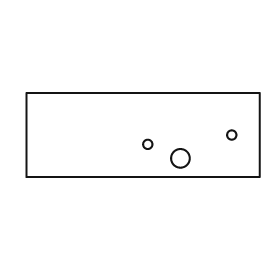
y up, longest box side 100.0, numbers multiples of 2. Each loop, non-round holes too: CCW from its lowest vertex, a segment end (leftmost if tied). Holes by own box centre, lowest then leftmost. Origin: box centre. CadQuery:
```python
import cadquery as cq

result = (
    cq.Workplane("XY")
    .moveTo(-50.0, -18.0)
    .lineTo(50.0, -18.0)
    .lineTo(50.0, 18.0)
    .lineTo(-50.0, 18.0)
    .close()
    .moveTo(16.0, -10.0)
    .circle(4.0)
    .moveTo(2.0, -4.0)
    .circle(2.0)
    .moveTo(38.0, 0.0)
    .circle(2.0)
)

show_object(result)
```